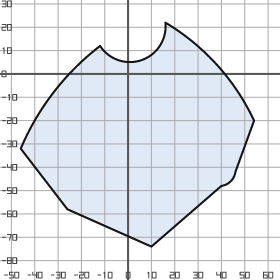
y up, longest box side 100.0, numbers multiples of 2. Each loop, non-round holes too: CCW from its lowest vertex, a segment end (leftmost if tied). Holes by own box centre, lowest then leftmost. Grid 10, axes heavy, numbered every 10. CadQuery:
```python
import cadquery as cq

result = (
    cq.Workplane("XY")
    .moveTo(10.0, -74.0)
    .lineTo(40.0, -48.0)
    .threePointArc((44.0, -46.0), (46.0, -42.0))
    .lineTo(54.0, -20.0)
    .threePointArc((38.0, 4.0), (16.0, 22.0))
    .threePointArc((6.0, 6.0), (-12.0, 12.0))
    .threePointArc((-32.0, -8.0), (-46.0, -32.0))
    .lineTo(-26.0, -58.0)
    .close()
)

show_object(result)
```